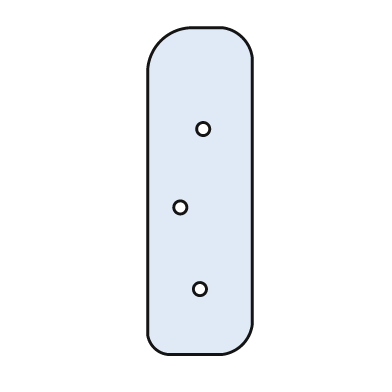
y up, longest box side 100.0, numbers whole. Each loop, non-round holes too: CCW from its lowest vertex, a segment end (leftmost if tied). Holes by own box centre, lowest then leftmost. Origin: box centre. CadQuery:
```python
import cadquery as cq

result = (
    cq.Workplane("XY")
    .moveTo(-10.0, -50.0)
    .lineTo(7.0, -50.0)
    .threePointArc((13.0, -47.0), (16.0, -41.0))
    .lineTo(16.0, 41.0)
    .threePointArc((13.0, 47.0), (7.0, 50.0))
    .lineTo(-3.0, 50.0)
    .threePointArc((-12.0, 46.0), (-16.0, 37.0))
    .lineTo(-16.0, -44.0)
    .threePointArc((-14.0, -48.0), (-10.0, -50.0))
    .close()
    .moveTo(0.0, -30.0)
    .circle(2.0)
    .moveTo(-6.0, -5.0)
    .circle(2.0)
    .moveTo(1.0, 19.0)
    .circle(2.0)
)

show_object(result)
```